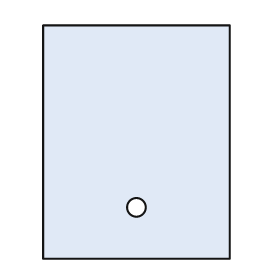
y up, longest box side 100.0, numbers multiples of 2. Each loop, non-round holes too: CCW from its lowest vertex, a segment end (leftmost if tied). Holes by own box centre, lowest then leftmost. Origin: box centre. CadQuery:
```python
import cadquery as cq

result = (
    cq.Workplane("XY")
    .moveTo(-40.0, -50.0)
    .lineTo(40.0, -50.0)
    .lineTo(40.0, 50.0)
    .lineTo(-40.0, 50.0)
    .close()
    .moveTo(0.0, -28.0)
    .circle(4.0)
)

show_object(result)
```